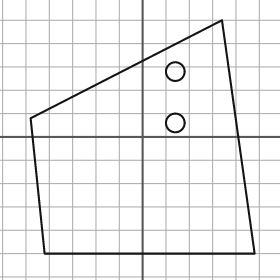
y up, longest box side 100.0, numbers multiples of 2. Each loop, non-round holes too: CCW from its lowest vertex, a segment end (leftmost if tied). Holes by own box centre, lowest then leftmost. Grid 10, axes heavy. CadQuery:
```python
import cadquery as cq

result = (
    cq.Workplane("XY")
    .moveTo(-42.0, -50.0)
    .lineTo(48.0, -50.0)
    .lineTo(34.0, 50.0)
    .lineTo(-48.0, 8.0)
    .close()
    .moveTo(14.0, 6.0)
    .circle(4.0)
    .moveTo(14.0, 28.0)
    .circle(4.0)
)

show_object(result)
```